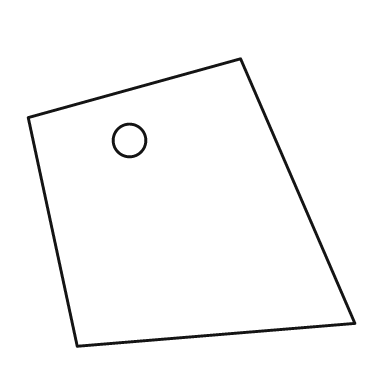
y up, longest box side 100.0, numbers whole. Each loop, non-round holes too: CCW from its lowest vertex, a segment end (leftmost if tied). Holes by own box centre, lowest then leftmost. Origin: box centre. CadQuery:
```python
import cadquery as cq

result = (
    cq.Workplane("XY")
    .moveTo(-35.0, -44.0)
    .lineTo(50.0, -37.0)
    .lineTo(15.0, 44.0)
    .lineTo(-50.0, 26.0)
    .close()
    .moveTo(-19.0, 19.0)
    .circle(5.0)
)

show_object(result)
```